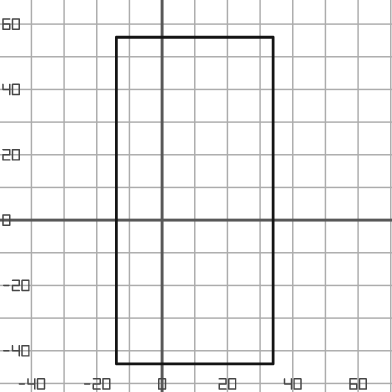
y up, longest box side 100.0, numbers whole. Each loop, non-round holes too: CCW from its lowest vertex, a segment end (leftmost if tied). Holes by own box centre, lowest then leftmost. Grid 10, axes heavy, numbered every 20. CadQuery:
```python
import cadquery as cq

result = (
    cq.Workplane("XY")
    .moveTo(-14.0, -44.0)
    .lineTo(34.0, -44.0)
    .lineTo(34.0, 56.0)
    .lineTo(-14.0, 56.0)
    .close()
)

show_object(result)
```